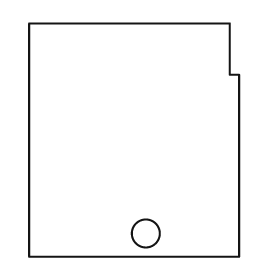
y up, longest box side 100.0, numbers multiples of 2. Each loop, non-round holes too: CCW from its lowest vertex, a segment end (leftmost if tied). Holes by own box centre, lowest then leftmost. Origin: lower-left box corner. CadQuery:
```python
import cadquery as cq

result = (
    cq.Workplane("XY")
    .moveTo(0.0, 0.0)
    .lineTo(90.0, 0.0)
    .lineTo(90.0, 78.0)
    .lineTo(86.0, 78.0)
    .lineTo(86.0, 100.0)
    .lineTo(0.0, 100.0)
    .close()
    .moveTo(50.0, 10.0)
    .circle(6.0)
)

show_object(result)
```